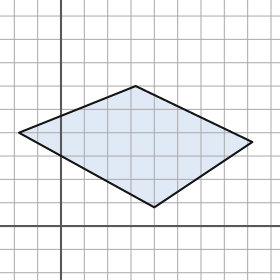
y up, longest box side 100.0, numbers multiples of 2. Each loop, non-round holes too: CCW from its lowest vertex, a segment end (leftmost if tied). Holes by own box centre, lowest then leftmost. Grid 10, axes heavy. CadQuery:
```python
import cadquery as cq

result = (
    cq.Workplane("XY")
    .moveTo(40.0, 8.0)
    .lineTo(82.0, 36.0)
    .lineTo(32.0, 60.0)
    .lineTo(-18.0, 40.0)
    .close()
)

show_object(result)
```